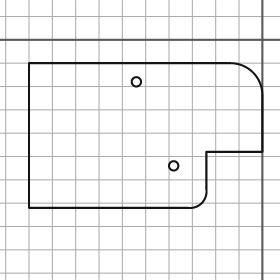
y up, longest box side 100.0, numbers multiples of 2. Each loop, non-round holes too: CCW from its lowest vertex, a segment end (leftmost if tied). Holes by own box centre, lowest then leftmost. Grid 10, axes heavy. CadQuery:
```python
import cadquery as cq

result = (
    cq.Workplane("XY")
    .moveTo(-100.0, -72.0)
    .lineTo(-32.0, -72.0)
    .threePointArc((-26.0, -70.0), (-24.0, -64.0))
    .lineTo(-24.0, -48.0)
    .lineTo(0.0, -48.0)
    .lineTo(0.0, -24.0)
    .threePointArc((-4.0, -14.0), (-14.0, -10.0))
    .lineTo(-100.0, -10.0)
    .close()
    .moveTo(-38.0, -54.0)
    .circle(2.0)
    .moveTo(-54.0, -18.0)
    .circle(2.0)
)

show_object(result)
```